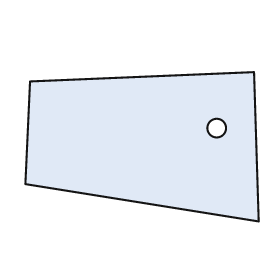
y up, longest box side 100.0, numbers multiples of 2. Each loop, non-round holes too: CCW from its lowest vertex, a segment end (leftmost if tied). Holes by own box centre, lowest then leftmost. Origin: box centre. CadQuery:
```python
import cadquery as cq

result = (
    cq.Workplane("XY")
    .moveTo(50.0, -32.0)
    .lineTo(48.0, 32.0)
    .lineTo(-48.0, 28.0)
    .lineTo(-50.0, -16.0)
    .close()
    .moveTo(32.0, 8.0)
    .circle(4.0)
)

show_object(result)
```